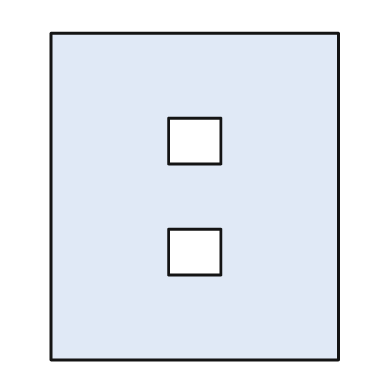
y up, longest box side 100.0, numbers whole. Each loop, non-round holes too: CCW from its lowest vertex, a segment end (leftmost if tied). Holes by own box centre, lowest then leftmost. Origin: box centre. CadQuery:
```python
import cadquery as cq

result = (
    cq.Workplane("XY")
    .moveTo(-44.0, -50.0)
    .lineTo(44.0, -50.0)
    .lineTo(44.0, 50.0)
    .lineTo(-44.0, 50.0)
    .close()
    .moveTo(-8.0, -24.0)
    .lineTo(8.0, -24.0)
    .lineTo(8.0, -10.0)
    .lineTo(-8.0, -10.0)
    .close()
    .moveTo(-8.0, 10.0)
    .lineTo(8.0, 10.0)
    .lineTo(8.0, 24.0)
    .lineTo(-8.0, 24.0)
    .close()
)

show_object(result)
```